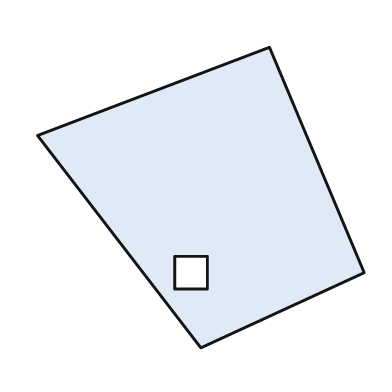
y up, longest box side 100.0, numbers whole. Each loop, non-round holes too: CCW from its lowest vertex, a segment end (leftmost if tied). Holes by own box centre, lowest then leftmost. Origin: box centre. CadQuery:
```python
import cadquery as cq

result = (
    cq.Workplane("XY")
    .moveTo(0.0, -46.0)
    .lineTo(50.0, -23.0)
    .lineTo(21.0, 46.0)
    .lineTo(-50.0, 19.0)
    .close()
    .moveTo(-8.0, -28.0)
    .lineTo(2.0, -28.0)
    .lineTo(2.0, -18.0)
    .lineTo(-8.0, -18.0)
    .close()
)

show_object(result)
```